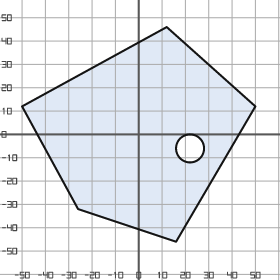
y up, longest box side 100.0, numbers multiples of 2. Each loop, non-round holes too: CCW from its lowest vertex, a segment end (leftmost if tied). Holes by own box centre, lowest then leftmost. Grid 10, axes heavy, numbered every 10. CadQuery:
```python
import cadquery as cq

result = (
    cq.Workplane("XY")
    .moveTo(16.0, -46.0)
    .lineTo(50.0, 12.0)
    .lineTo(12.0, 46.0)
    .lineTo(-50.0, 12.0)
    .lineTo(-26.0, -32.0)
    .close()
    .moveTo(22.0, -6.0)
    .circle(6.0)
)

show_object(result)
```